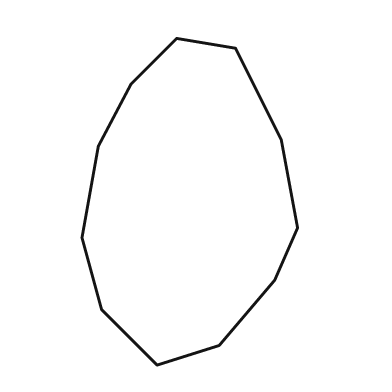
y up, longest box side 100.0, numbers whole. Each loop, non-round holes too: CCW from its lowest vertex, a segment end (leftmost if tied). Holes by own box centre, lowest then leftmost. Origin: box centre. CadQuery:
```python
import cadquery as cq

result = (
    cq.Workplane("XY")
    .moveTo(-10.0, -50.0)
    .lineTo(9.0, -44.0)
    .lineTo(26.0, -24.0)
    .lineTo(33.0, -8.0)
    .lineTo(28.0, 19.0)
    .lineTo(14.0, 47.0)
    .lineTo(-4.0, 50.0)
    .lineTo(-18.0, 36.0)
    .lineTo(-28.0, 17.0)
    .lineTo(-33.0, -11.0)
    .lineTo(-27.0, -33.0)
    .close()
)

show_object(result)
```